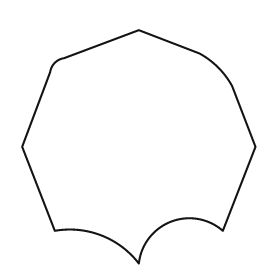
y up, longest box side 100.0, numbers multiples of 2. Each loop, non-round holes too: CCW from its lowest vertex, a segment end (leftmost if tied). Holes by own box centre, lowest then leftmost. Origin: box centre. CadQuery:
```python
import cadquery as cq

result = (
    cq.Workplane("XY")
    .moveTo(0.0, -50.0)
    .threePointArc((14.0, -32.0), (36.0, -36.0))
    .lineTo(50.0, 0.0)
    .lineTo(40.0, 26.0)
    .threePointArc((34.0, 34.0), (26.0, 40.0))
    .lineTo(0.0, 50.0)
    .lineTo(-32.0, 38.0)
    .threePointArc((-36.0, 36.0), (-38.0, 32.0))
    .lineTo(-50.0, 0.0)
    .lineTo(-36.0, -36.0)
    .threePointArc((-16.0, -38.0), (0.0, -50.0))
    .close()
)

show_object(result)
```